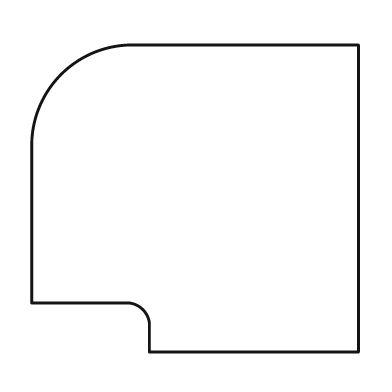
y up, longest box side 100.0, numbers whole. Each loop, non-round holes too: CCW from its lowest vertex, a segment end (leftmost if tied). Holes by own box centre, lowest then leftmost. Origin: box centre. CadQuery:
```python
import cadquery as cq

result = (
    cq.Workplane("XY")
    .moveTo(-14.0, -47.0)
    .lineTo(50.0, -47.0)
    .lineTo(50.0, 47.0)
    .lineTo(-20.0, 47.0)
    .threePointArc((-41.0, 38.0), (-50.0, 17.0))
    .lineTo(-50.0, -32.0)
    .lineTo(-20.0, -32.0)
    .threePointArc((-16.0, -34.0), (-14.0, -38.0))
    .close()
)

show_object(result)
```